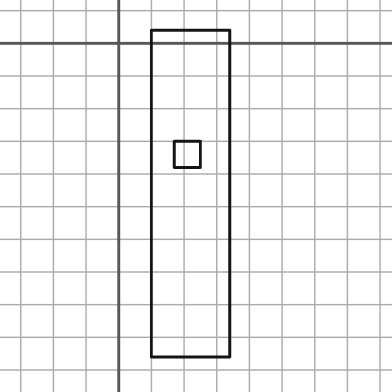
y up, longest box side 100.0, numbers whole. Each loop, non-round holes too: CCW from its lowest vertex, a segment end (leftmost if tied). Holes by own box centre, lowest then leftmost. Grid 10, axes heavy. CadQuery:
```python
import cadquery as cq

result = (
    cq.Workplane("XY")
    .moveTo(10.0, -96.0)
    .lineTo(34.0, -96.0)
    .lineTo(34.0, 4.0)
    .lineTo(10.0, 4.0)
    .close()
    .moveTo(17.0, -38.0)
    .lineTo(25.0, -38.0)
    .lineTo(25.0, -30.0)
    .lineTo(17.0, -30.0)
    .close()
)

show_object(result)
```